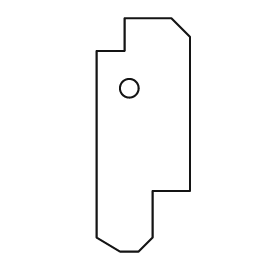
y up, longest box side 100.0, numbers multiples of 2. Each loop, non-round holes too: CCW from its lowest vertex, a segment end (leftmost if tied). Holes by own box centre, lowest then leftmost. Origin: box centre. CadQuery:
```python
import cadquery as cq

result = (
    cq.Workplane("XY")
    .moveTo(-10.0, -50.0)
    .lineTo(-2.0, -50.0)
    .lineTo(4.0, -44.0)
    .lineTo(4.0, -24.0)
    .lineTo(20.0, -24.0)
    .lineTo(20.0, 42.0)
    .lineTo(12.0, 50.0)
    .lineTo(-8.0, 50.0)
    .lineTo(-8.0, 36.0)
    .lineTo(-20.0, 36.0)
    .lineTo(-20.0, -44.0)
    .close()
    .moveTo(-6.0, 20.0)
    .circle(4.0)
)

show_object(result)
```